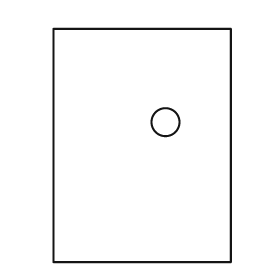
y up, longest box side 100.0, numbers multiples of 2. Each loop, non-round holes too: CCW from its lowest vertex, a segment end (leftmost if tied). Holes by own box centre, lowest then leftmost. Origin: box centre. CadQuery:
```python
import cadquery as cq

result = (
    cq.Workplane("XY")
    .moveTo(-38.0, -50.0)
    .lineTo(38.0, -50.0)
    .lineTo(38.0, 50.0)
    .lineTo(-38.0, 50.0)
    .close()
    .moveTo(10.0, 10.0)
    .circle(6.0)
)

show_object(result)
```